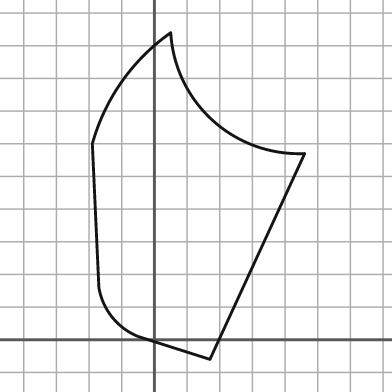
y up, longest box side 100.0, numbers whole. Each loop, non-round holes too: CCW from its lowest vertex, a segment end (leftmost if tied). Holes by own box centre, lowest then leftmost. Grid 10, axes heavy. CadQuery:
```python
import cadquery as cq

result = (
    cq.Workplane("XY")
    .moveTo(17.0, -6.0)
    .lineTo(46.0, 57.0)
    .threePointArc((18.0, 67.0), (5.0, 94.0))
    .threePointArc((-10.0, 79.0), (-19.0, 60.0))
    .lineTo(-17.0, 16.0)
    .threePointArc((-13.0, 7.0), (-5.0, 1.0))
    .close()
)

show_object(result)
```